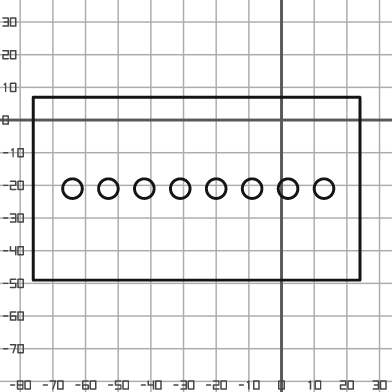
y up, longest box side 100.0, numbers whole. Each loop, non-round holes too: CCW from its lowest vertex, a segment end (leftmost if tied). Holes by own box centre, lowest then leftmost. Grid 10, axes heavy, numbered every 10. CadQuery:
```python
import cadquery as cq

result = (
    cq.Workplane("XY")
    .moveTo(-76.0, -49.0)
    .lineTo(24.0, -49.0)
    .lineTo(24.0, 7.0)
    .lineTo(-76.0, 7.0)
    .close()
    .moveTo(-64.0, -21.0)
    .circle(3.0)
    .moveTo(-53.0, -21.0)
    .circle(3.0)
    .moveTo(-42.0, -21.0)
    .circle(3.0)
    .moveTo(-31.0, -21.0)
    .circle(3.0)
    .moveTo(-20.0, -21.0)
    .circle(3.0)
    .moveTo(-9.0, -21.0)
    .circle(3.0)
    .moveTo(2.0, -21.0)
    .circle(3.0)
    .moveTo(13.0, -21.0)
    .circle(3.0)
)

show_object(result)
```